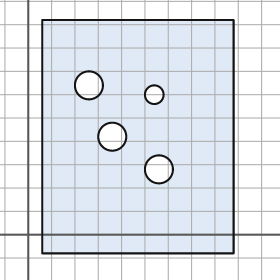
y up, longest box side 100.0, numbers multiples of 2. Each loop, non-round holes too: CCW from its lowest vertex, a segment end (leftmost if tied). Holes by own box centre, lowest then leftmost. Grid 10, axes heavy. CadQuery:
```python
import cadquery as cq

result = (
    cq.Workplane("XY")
    .moveTo(6.0, -8.0)
    .lineTo(88.0, -8.0)
    .lineTo(88.0, 92.0)
    .lineTo(6.0, 92.0)
    .close()
    .moveTo(56.0, 28.0)
    .circle(6.0)
    .moveTo(36.0, 42.0)
    .circle(6.0)
    .moveTo(54.0, 60.0)
    .circle(4.0)
    .moveTo(26.0, 64.0)
    .circle(6.0)
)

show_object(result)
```